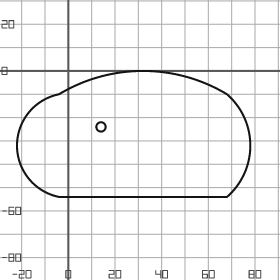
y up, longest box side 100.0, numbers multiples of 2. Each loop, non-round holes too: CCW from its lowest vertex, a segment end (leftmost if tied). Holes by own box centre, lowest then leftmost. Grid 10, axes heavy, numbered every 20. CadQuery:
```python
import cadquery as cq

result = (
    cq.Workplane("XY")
    .moveTo(-4.0, -54.0)
    .lineTo(68.0, -54.0)
    .threePointArc((78.0, -32.0), (68.0, -10.0))
    .threePointArc((32.0, 0.0), (-4.0, -10.0))
    .threePointArc((-22.0, -32.0), (-4.0, -54.0))
    .close()
    .moveTo(14.0, -24.0)
    .circle(2.0)
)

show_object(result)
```